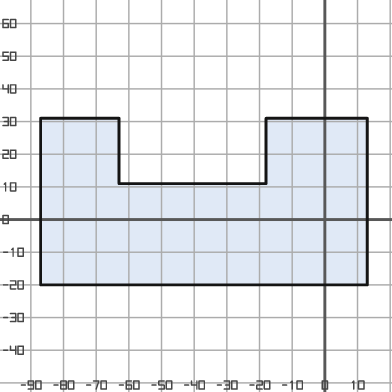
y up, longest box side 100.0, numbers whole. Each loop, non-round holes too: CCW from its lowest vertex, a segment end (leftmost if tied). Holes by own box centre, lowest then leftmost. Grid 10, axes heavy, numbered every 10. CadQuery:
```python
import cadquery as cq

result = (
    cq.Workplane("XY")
    .moveTo(-87.0, -20.0)
    .lineTo(13.0, -20.0)
    .lineTo(13.0, 31.0)
    .lineTo(-18.0, 31.0)
    .lineTo(-18.0, 11.0)
    .lineTo(-63.0, 11.0)
    .lineTo(-63.0, 31.0)
    .lineTo(-87.0, 31.0)
    .close()
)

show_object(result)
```